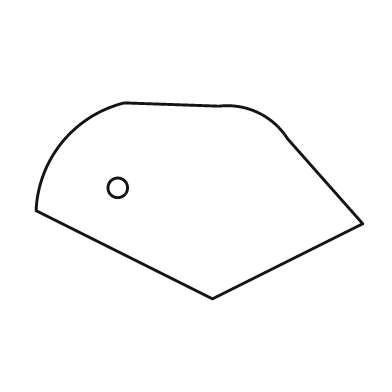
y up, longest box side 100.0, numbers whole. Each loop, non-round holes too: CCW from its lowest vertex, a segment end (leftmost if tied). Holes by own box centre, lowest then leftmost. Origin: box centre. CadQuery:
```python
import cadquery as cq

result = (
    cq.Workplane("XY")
    .moveTo(4.0, -30.0)
    .lineTo(50.0, -7.0)
    .lineTo(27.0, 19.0)
    .threePointArc((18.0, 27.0), (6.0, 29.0))
    .lineTo(-23.0, 30.0)
    .threePointArc((-42.0, 18.0), (-50.0, -3.0))
    .close()
    .moveTo(-25.0, 4.0)
    .circle(3.0)
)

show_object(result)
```